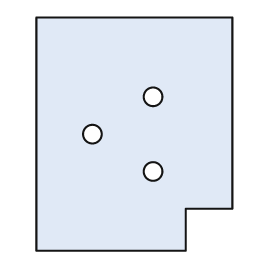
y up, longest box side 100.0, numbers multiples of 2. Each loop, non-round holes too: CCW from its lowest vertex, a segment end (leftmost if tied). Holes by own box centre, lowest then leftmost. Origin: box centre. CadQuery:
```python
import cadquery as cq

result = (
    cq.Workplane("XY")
    .moveTo(-42.0, -50.0)
    .lineTo(22.0, -50.0)
    .lineTo(22.0, -32.0)
    .lineTo(42.0, -32.0)
    .lineTo(42.0, 50.0)
    .lineTo(-42.0, 50.0)
    .close()
    .moveTo(8.0, -16.0)
    .circle(4.0)
    .moveTo(-18.0, 0.0)
    .circle(4.0)
    .moveTo(8.0, 16.0)
    .circle(4.0)
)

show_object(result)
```